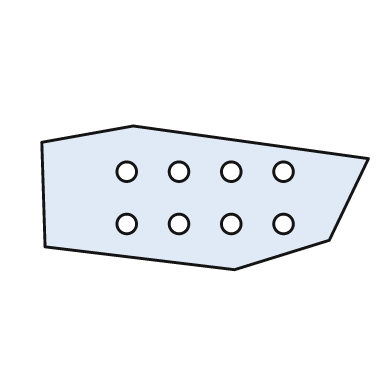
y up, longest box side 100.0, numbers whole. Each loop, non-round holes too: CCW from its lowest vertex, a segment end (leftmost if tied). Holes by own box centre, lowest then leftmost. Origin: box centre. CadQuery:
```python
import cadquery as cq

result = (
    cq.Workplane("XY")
    .moveTo(9.0, -22.0)
    .lineTo(38.0, -13.0)
    .lineTo(50.0, 12.0)
    .lineTo(-22.0, 22.0)
    .lineTo(-50.0, 17.0)
    .lineTo(-49.0, -15.0)
    .close()
    .moveTo(-24.0, -8.0)
    .circle(3.0)
    .moveTo(-8.0, -8.0)
    .circle(3.0)
    .moveTo(8.0, -8.0)
    .circle(3.0)
    .moveTo(24.0, -8.0)
    .circle(3.0)
    .moveTo(-24.0, 8.0)
    .circle(3.0)
    .moveTo(-8.0, 8.0)
    .circle(3.0)
    .moveTo(8.0, 8.0)
    .circle(3.0)
    .moveTo(24.0, 8.0)
    .circle(3.0)
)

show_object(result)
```